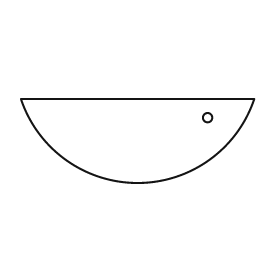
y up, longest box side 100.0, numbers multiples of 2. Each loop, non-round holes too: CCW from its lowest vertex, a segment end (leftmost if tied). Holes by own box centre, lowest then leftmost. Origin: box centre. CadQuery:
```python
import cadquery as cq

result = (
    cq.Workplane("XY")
    .moveTo(-50.0, 18.0)
    .threePointArc((0.0, -18.0), (50.0, 18.0))
    .close()
    .moveTo(30.0, 10.0)
    .circle(2.0)
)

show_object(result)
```